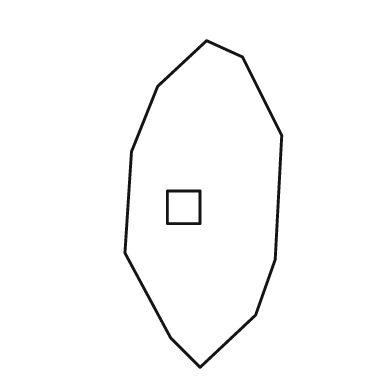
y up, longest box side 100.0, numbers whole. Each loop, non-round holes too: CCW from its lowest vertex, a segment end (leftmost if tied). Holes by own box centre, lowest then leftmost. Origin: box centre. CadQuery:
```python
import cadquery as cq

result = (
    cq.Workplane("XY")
    .moveTo(-1.0, -50.0)
    .lineTo(16.0, -34.0)
    .lineTo(22.0, -17.0)
    .lineTo(24.0, 21.0)
    .lineTo(12.0, 45.0)
    .lineTo(1.0, 50.0)
    .lineTo(-14.0, 36.0)
    .lineTo(-22.0, 16.0)
    .lineTo(-24.0, -15.0)
    .lineTo(-10.0, -41.0)
    .close()
    .moveTo(-11.0, -6.0)
    .lineTo(-1.0, -6.0)
    .lineTo(-1.0, 4.0)
    .lineTo(-11.0, 4.0)
    .close()
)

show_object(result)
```